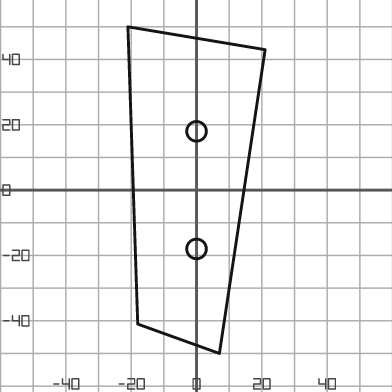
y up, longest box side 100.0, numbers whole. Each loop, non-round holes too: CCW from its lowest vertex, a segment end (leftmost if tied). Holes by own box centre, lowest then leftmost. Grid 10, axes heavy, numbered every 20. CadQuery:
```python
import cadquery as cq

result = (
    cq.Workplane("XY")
    .moveTo(7.0, -50.0)
    .lineTo(21.0, 43.0)
    .lineTo(-21.0, 50.0)
    .lineTo(-18.0, -41.0)
    .close()
    .moveTo(0.0, -18.0)
    .circle(3.0)
    .moveTo(0.0, 18.0)
    .circle(3.0)
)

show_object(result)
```